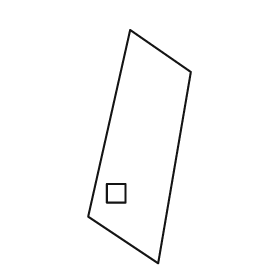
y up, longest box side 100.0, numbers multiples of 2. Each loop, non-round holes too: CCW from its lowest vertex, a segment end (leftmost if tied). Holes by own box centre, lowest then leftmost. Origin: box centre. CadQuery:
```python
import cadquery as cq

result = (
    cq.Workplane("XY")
    .moveTo(8.0, -50.0)
    .lineTo(22.0, 32.0)
    .lineTo(-4.0, 50.0)
    .lineTo(-22.0, -30.0)
    .close()
    .moveTo(-14.0, -24.0)
    .lineTo(-6.0, -24.0)
    .lineTo(-6.0, -16.0)
    .lineTo(-14.0, -16.0)
    .close()
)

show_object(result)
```